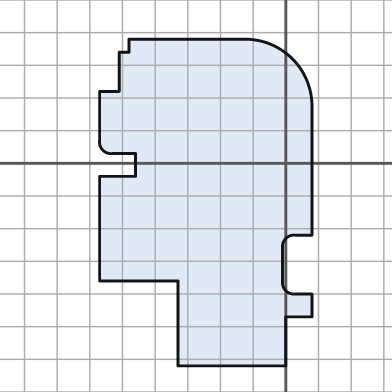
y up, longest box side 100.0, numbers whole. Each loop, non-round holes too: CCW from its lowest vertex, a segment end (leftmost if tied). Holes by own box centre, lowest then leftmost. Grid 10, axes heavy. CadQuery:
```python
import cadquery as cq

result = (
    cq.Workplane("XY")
    .moveTo(-33.0, -62.0)
    .lineTo(0.0, -62.0)
    .lineTo(0.0, -47.0)
    .lineTo(8.0, -47.0)
    .lineTo(8.0, -40.0)
    .lineTo(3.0, -40.0)
    .threePointArc((0.0, -39.0), (-1.0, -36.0))
    .lineTo(-1.0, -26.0)
    .threePointArc((0.0, -23.0), (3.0, -22.0))
    .lineTo(8.0, -22.0)
    .lineTo(8.0, 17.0)
    .threePointArc((2.0, 32.0), (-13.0, 38.0))
    .lineTo(-48.0, 38.0)
    .lineTo(-48.0, 34.0)
    .lineTo(-51.0, 34.0)
    .lineTo(-51.0, 22.0)
    .lineTo(-57.0, 22.0)
    .lineTo(-57.0, 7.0)
    .threePointArc((-56.0, 4.0), (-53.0, 3.0))
    .lineTo(-46.0, 3.0)
    .lineTo(-46.0, -4.0)
    .lineTo(-57.0, -4.0)
    .lineTo(-57.0, -36.0)
    .lineTo(-33.0, -36.0)
    .close()
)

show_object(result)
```